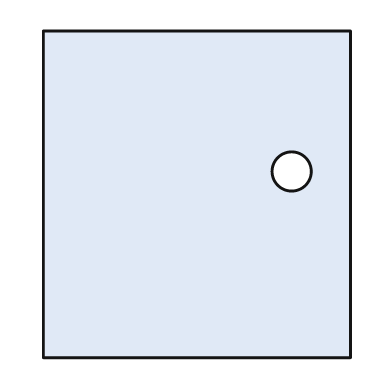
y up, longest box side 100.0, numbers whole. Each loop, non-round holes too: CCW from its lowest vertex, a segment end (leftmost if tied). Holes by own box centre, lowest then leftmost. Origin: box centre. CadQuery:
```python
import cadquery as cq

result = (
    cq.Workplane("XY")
    .moveTo(-47.0, -50.0)
    .lineTo(47.0, -50.0)
    .lineTo(47.0, 50.0)
    .lineTo(-47.0, 50.0)
    .close()
    .moveTo(29.0, 7.0)
    .circle(6.0)
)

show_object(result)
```